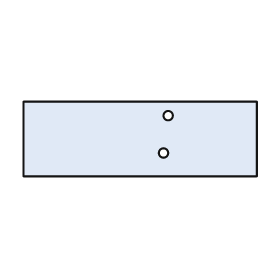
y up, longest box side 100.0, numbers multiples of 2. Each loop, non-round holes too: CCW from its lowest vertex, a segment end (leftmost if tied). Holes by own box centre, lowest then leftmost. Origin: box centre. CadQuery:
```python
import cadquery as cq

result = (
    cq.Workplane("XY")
    .moveTo(-50.0, -16.0)
    .lineTo(50.0, -16.0)
    .lineTo(50.0, 16.0)
    .lineTo(-50.0, 16.0)
    .close()
    .moveTo(10.0, -6.0)
    .circle(2.0)
    .moveTo(12.0, 10.0)
    .circle(2.0)
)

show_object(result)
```